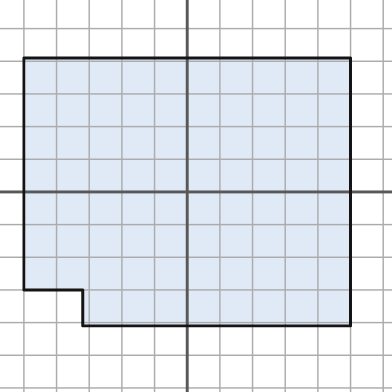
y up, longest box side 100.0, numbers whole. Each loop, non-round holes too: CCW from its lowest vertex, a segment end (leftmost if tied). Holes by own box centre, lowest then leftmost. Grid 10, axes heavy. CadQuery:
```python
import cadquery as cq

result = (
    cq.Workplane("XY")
    .moveTo(-32.0, -41.0)
    .lineTo(50.0, -41.0)
    .lineTo(50.0, 41.0)
    .lineTo(-50.0, 41.0)
    .lineTo(-50.0, -30.0)
    .lineTo(-32.0, -30.0)
    .close()
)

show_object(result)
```